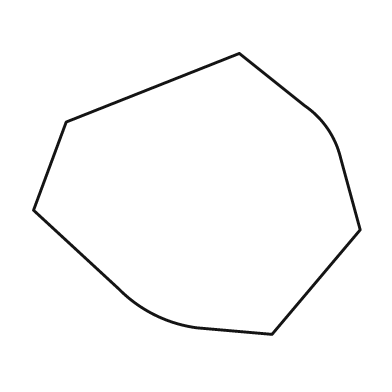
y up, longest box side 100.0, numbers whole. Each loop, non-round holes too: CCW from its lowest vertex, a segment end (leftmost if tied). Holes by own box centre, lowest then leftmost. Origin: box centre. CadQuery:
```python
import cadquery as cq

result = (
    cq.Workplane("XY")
    .moveTo(23.0, -43.0)
    .lineTo(50.0, -11.0)
    .lineTo(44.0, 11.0)
    .threePointArc((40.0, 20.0), (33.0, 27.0))
    .lineTo(13.0, 43.0)
    .lineTo(-40.0, 22.0)
    .lineTo(-50.0, -5.0)
    .lineTo(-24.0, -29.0)
    .threePointArc((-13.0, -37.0), (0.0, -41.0))
    .close()
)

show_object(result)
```